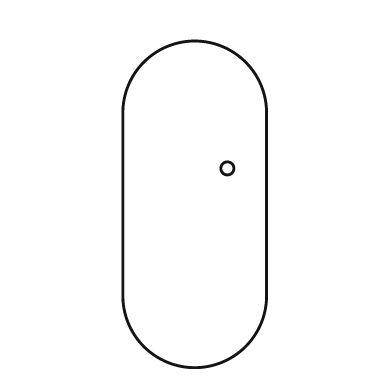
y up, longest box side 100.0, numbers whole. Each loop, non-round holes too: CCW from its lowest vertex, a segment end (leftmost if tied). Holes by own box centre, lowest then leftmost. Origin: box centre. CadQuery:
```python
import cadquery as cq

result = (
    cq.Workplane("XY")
    .moveTo(-22.0, -28.0)
    .threePointArc((0.0, -50.0), (22.0, -28.0))
    .lineTo(22.0, 28.0)
    .threePointArc((0.0, 50.0), (-22.0, 28.0))
    .close()
    .moveTo(10.0, 11.0)
    .circle(2.0)
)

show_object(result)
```